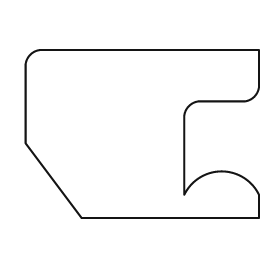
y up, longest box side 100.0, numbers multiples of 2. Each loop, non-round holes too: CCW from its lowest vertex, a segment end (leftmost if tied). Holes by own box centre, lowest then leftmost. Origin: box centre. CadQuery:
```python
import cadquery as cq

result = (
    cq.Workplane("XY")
    .moveTo(-26.0, -36.0)
    .lineTo(50.0, -36.0)
    .lineTo(50.0, -26.0)
    .threePointArc((34.0, -16.0), (18.0, -26.0))
    .lineTo(18.0, 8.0)
    .threePointArc((20.0, 12.0), (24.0, 14.0))
    .lineTo(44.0, 14.0)
    .threePointArc((48.0, 16.0), (50.0, 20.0))
    .lineTo(50.0, 36.0)
    .lineTo(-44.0, 36.0)
    .threePointArc((-48.0, 34.0), (-50.0, 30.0))
    .lineTo(-50.0, -4.0)
    .close()
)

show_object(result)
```